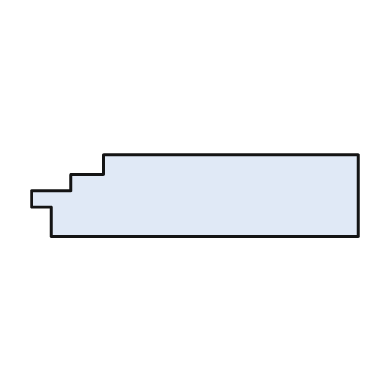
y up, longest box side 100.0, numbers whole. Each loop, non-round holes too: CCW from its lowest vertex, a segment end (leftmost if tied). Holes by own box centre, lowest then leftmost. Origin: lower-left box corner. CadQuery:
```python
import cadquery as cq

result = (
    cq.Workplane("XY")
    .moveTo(6.0, 0.0)
    .lineTo(100.0, 0.0)
    .lineTo(100.0, 25.0)
    .lineTo(22.0, 25.0)
    .lineTo(22.0, 19.0)
    .lineTo(12.0, 19.0)
    .lineTo(12.0, 14.0)
    .lineTo(0.0, 14.0)
    .lineTo(0.0, 9.0)
    .lineTo(6.0, 9.0)
    .close()
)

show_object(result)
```